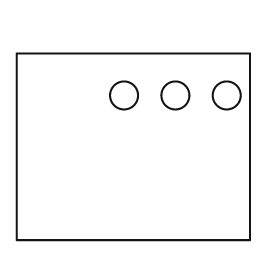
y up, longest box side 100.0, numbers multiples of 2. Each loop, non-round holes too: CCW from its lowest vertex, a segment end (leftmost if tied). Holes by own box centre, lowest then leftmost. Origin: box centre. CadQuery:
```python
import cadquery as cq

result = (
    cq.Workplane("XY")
    .moveTo(-50.0, -40.0)
    .lineTo(50.0, -40.0)
    .lineTo(50.0, 40.0)
    .lineTo(-50.0, 40.0)
    .close()
    .moveTo(-4.0, 22.0)
    .circle(6.0)
    .moveTo(18.0, 22.0)
    .circle(6.0)
    .moveTo(40.0, 22.0)
    .circle(6.0)
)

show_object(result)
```